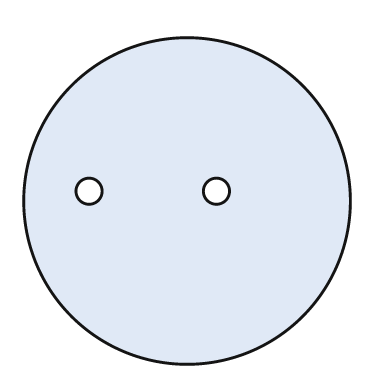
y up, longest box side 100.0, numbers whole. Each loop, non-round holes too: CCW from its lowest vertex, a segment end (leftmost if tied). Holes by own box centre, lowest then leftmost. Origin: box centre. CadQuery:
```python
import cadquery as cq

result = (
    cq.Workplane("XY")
    .moveTo(0.0, 0.0)
    .circle(50.0)
    .moveTo(-30.0, 3.0)
    .circle(4.0)
    .moveTo(9.0, 3.0)
    .circle(4.0)
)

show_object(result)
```